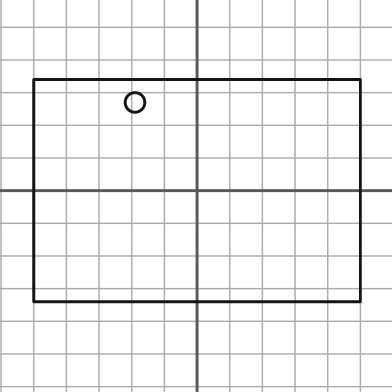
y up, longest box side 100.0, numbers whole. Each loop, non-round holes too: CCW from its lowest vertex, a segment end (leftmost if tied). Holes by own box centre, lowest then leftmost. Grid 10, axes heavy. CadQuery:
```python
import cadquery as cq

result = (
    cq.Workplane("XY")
    .moveTo(-50.0, -34.0)
    .lineTo(50.0, -34.0)
    .lineTo(50.0, 34.0)
    .lineTo(-50.0, 34.0)
    .close()
    .moveTo(-19.0, 27.0)
    .circle(3.0)
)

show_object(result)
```